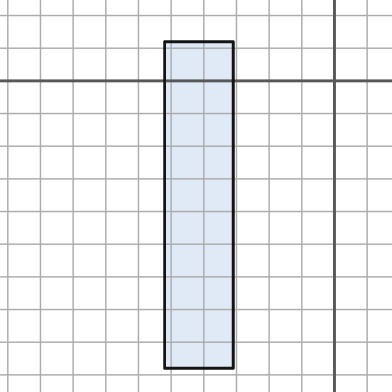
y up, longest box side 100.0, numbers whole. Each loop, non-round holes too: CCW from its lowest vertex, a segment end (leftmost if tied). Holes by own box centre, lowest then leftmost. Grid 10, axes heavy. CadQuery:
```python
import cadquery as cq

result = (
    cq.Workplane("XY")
    .moveTo(-52.0, -88.0)
    .lineTo(-31.0, -88.0)
    .lineTo(-31.0, 12.0)
    .lineTo(-52.0, 12.0)
    .close()
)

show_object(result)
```